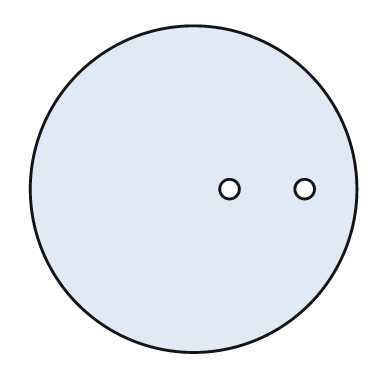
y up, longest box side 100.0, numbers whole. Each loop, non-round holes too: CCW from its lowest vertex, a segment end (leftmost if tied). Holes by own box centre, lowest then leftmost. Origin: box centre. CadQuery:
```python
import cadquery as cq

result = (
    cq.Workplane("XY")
    .moveTo(0.0, 0.0)
    .circle(50.0)
    .moveTo(11.0, 0.0)
    .circle(3.0)
    .moveTo(34.0, 0.0)
    .circle(3.0)
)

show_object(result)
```